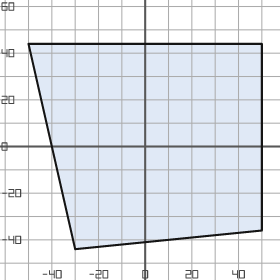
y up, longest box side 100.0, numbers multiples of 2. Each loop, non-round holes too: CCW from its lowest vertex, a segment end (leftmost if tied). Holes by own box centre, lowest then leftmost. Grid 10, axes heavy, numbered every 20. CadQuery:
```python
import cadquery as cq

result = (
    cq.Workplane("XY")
    .moveTo(-30.0, -44.0)
    .lineTo(50.0, -36.0)
    .lineTo(50.0, 44.0)
    .lineTo(-50.0, 44.0)
    .close()
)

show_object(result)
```